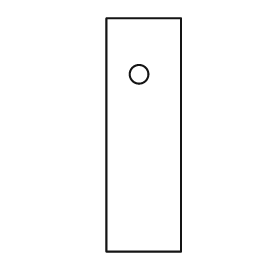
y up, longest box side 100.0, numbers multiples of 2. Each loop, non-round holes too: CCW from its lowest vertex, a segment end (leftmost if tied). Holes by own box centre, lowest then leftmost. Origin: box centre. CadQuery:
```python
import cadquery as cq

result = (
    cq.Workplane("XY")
    .moveTo(-16.0, -50.0)
    .lineTo(16.0, -50.0)
    .lineTo(16.0, 50.0)
    .lineTo(-16.0, 50.0)
    .close()
    .moveTo(-2.0, 26.0)
    .circle(4.0)
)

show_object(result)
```